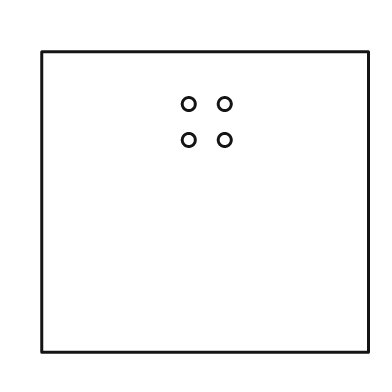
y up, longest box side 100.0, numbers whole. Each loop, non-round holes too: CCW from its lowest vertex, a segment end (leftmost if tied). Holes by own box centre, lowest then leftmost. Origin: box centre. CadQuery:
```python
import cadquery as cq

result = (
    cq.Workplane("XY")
    .moveTo(-50.0, -46.0)
    .lineTo(50.0, -46.0)
    .lineTo(50.0, 46.0)
    .lineTo(-50.0, 46.0)
    .close()
    .moveTo(-5.0, 19.0)
    .circle(2.0)
    .moveTo(6.0, 19.0)
    .circle(2.0)
    .moveTo(-5.0, 30.0)
    .circle(2.0)
    .moveTo(6.0, 30.0)
    .circle(2.0)
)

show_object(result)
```